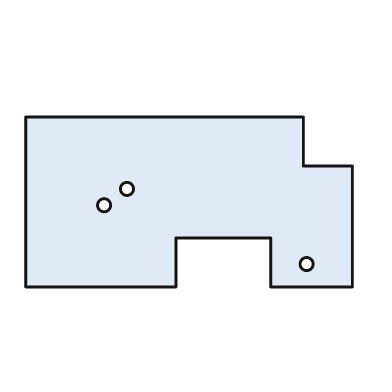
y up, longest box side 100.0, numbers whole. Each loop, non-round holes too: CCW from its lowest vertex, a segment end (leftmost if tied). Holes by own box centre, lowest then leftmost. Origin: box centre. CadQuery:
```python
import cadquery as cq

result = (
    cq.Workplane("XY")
    .moveTo(-50.0, -26.0)
    .lineTo(-4.0, -26.0)
    .lineTo(-4.0, -11.0)
    .lineTo(25.0, -11.0)
    .lineTo(25.0, -26.0)
    .lineTo(50.0, -26.0)
    .lineTo(50.0, 11.0)
    .lineTo(35.0, 11.0)
    .lineTo(35.0, 26.0)
    .lineTo(-50.0, 26.0)
    .close()
    .moveTo(36.0, -19.0)
    .circle(2.0)
    .moveTo(-26.0, -1.0)
    .circle(2.0)
    .moveTo(-19.0, 4.0)
    .circle(2.0)
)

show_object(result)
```